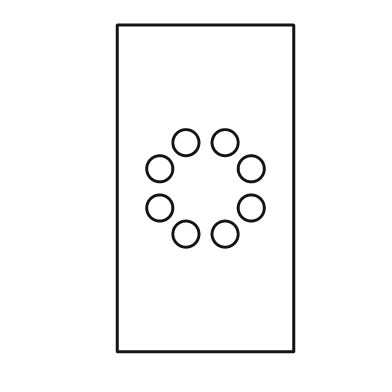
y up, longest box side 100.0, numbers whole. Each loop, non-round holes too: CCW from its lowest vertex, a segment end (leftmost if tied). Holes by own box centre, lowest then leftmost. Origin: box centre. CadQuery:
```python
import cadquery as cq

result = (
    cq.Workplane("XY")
    .moveTo(-27.0, -50.0)
    .lineTo(27.0, -50.0)
    .lineTo(27.0, 50.0)
    .lineTo(-27.0, 50.0)
    .close()
    .moveTo(-6.0, -14.0)
    .circle(4.0)
    .moveTo(6.0, -14.0)
    .circle(4.0)
    .moveTo(-14.0, -6.0)
    .circle(4.0)
    .moveTo(14.0, -6.0)
    .circle(4.0)
    .moveTo(-14.0, 6.0)
    .circle(4.0)
    .moveTo(14.0, 6.0)
    .circle(4.0)
    .moveTo(-6.0, 14.0)
    .circle(4.0)
    .moveTo(6.0, 14.0)
    .circle(4.0)
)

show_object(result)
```